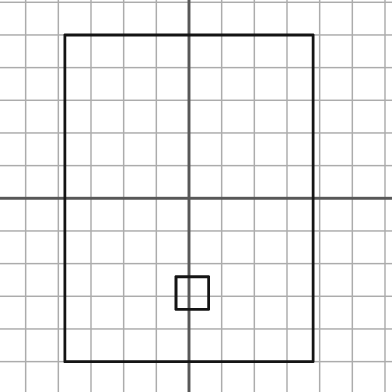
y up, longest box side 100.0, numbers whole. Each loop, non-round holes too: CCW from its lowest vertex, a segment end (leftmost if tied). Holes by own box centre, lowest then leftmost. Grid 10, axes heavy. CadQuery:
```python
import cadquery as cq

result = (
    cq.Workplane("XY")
    .moveTo(-38.0, -50.0)
    .lineTo(38.0, -50.0)
    .lineTo(38.0, 50.0)
    .lineTo(-38.0, 50.0)
    .close()
    .moveTo(-4.0, -34.0)
    .lineTo(6.0, -34.0)
    .lineTo(6.0, -24.0)
    .lineTo(-4.0, -24.0)
    .close()
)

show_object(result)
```